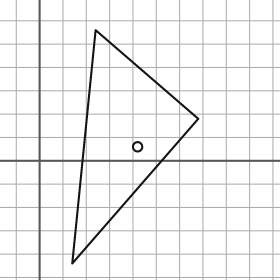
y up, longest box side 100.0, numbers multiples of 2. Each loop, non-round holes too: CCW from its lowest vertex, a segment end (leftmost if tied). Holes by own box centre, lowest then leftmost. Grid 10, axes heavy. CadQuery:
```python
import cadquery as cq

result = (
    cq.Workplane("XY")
    .moveTo(14.0, -44.0)
    .lineTo(68.0, 18.0)
    .lineTo(24.0, 56.0)
    .close()
    .moveTo(42.0, 6.0)
    .circle(2.0)
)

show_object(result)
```